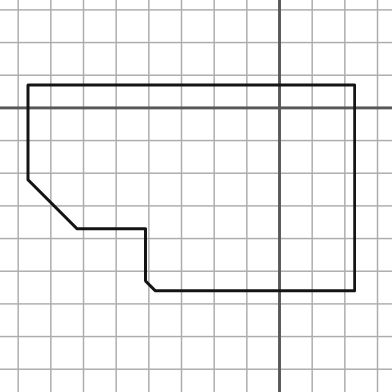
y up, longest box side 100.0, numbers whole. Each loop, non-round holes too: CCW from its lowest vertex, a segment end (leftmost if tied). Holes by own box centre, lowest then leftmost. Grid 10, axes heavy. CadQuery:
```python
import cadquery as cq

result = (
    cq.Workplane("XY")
    .moveTo(-38.0, -56.0)
    .lineTo(23.0, -56.0)
    .lineTo(23.0, 7.0)
    .lineTo(-77.0, 7.0)
    .lineTo(-77.0, -22.0)
    .lineTo(-62.0, -37.0)
    .lineTo(-41.0, -37.0)
    .lineTo(-41.0, -53.0)
    .close()
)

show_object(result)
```